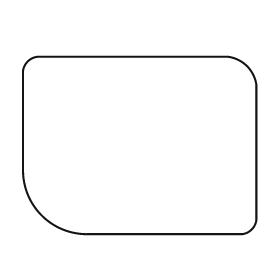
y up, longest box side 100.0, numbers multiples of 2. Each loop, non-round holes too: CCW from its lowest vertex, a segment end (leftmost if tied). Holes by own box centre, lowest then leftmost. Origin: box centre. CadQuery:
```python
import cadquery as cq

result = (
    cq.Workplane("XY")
    .moveTo(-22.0, -38.0)
    .lineTo(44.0, -38.0)
    .threePointArc((48.0, -36.0), (50.0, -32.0))
    .lineTo(50.0, 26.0)
    .threePointArc((46.0, 34.0), (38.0, 38.0))
    .lineTo(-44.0, 38.0)
    .threePointArc((-48.0, 36.0), (-50.0, 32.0))
    .lineTo(-50.0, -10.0)
    .threePointArc((-42.0, -30.0), (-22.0, -38.0))
    .close()
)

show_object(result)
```